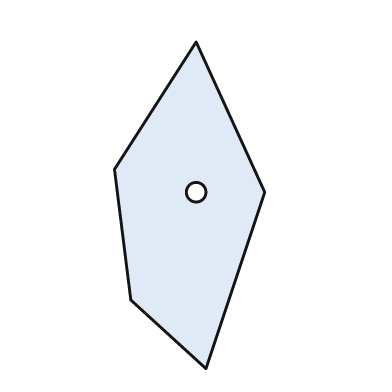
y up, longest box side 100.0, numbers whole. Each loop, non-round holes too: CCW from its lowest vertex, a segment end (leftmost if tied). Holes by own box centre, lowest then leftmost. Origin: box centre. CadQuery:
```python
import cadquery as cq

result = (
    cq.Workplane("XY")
    .moveTo(5.0, -50.0)
    .lineTo(23.0, 4.0)
    .lineTo(2.0, 50.0)
    .lineTo(-23.0, 11.0)
    .lineTo(-18.0, -29.0)
    .close()
    .moveTo(2.0, 4.0)
    .circle(3.0)
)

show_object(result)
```